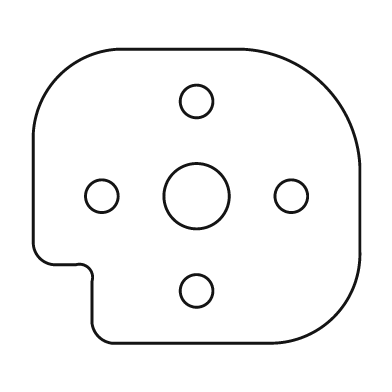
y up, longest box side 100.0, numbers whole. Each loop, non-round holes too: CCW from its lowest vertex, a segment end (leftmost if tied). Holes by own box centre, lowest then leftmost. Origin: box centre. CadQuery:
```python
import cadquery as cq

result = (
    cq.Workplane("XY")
    .moveTo(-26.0, -45.0)
    .lineTo(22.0, -45.0)
    .threePointArc((42.0, -37.0), (50.0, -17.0))
    .lineTo(50.0, 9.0)
    .threePointArc((39.0, 34.0), (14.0, 45.0))
    .lineTo(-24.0, 45.0)
    .threePointArc((-42.0, 37.0), (-50.0, 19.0))
    .lineTo(-50.0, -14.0)
    .threePointArc((-48.0, -19.0), (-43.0, -21.0))
    .lineTo(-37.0, -21.0)
    .threePointArc((-33.0, -22.0), (-32.0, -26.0))
    .lineTo(-32.0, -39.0)
    .threePointArc((-30.0, -43.0), (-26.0, -45.0))
    .close()
    .moveTo(0.0, -29.0)
    .circle(5.0)
    .moveTo(-29.0, 0.0)
    .circle(5.0)
    .moveTo(0.0, 0.0)
    .circle(10.0)
    .moveTo(29.0, 0.0)
    .circle(5.0)
    .moveTo(0.0, 29.0)
    .circle(5.0)
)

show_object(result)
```